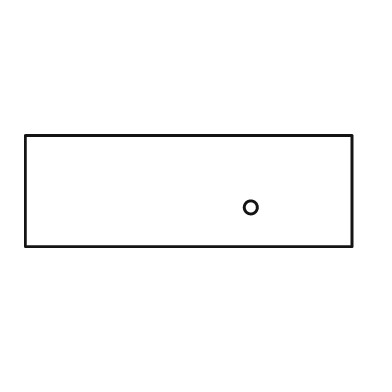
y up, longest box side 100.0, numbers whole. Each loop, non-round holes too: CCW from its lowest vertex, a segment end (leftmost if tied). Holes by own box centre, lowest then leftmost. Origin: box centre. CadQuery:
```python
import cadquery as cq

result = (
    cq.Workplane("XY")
    .moveTo(-50.0, -17.0)
    .lineTo(50.0, -17.0)
    .lineTo(50.0, 17.0)
    .lineTo(-50.0, 17.0)
    .close()
    .moveTo(19.0, -5.0)
    .circle(2.0)
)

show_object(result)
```